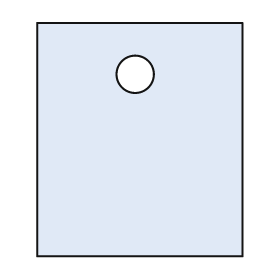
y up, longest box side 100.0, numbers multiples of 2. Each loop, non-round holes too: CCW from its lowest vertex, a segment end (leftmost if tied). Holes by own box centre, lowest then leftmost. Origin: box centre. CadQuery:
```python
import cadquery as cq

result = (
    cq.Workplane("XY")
    .moveTo(-44.0, -50.0)
    .lineTo(44.0, -50.0)
    .lineTo(44.0, 50.0)
    .lineTo(-44.0, 50.0)
    .close()
    .moveTo(-2.0, 28.0)
    .circle(8.0)
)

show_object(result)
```